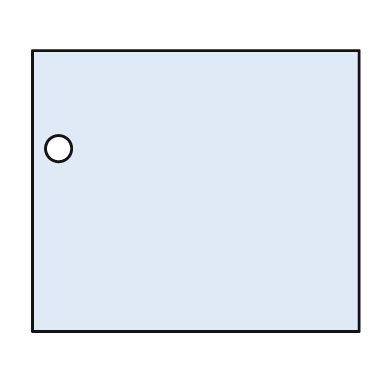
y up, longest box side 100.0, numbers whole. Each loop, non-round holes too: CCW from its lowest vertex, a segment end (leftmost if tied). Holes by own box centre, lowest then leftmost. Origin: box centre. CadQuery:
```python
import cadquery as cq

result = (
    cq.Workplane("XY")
    .moveTo(-50.0, -43.0)
    .lineTo(50.0, -43.0)
    .lineTo(50.0, 43.0)
    .lineTo(-50.0, 43.0)
    .close()
    .moveTo(-42.0, 13.0)
    .circle(4.0)
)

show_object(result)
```